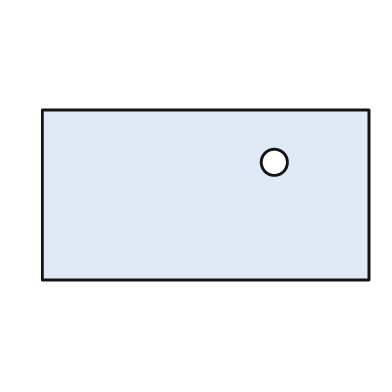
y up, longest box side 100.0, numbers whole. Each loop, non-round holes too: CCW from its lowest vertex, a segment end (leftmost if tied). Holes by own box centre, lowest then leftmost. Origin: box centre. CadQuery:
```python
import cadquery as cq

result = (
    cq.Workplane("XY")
    .moveTo(-50.0, -26.0)
    .lineTo(50.0, -26.0)
    .lineTo(50.0, 26.0)
    .lineTo(-50.0, 26.0)
    .close()
    .moveTo(21.0, 10.0)
    .circle(4.0)
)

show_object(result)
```